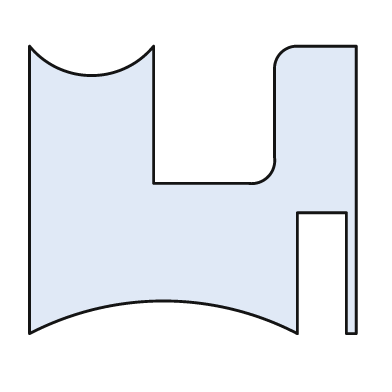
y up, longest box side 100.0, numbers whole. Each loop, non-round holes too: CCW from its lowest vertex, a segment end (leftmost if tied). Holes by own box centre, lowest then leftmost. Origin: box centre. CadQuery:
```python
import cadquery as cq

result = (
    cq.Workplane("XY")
    .moveTo(-50.0, -44.0)
    .threePointArc((-9.0, -34.0), (32.0, -44.0))
    .lineTo(32.0, -7.0)
    .lineTo(47.0, -7.0)
    .lineTo(47.0, -44.0)
    .lineTo(50.0, -44.0)
    .lineTo(50.0, 44.0)
    .lineTo(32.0, 44.0)
    .threePointArc((27.0, 42.0), (25.0, 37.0))
    .lineTo(25.0, 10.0)
    .threePointArc((23.0, 4.0), (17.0, 2.0))
    .lineTo(-12.0, 2.0)
    .lineTo(-12.0, 44.0)
    .threePointArc((-31.0, 35.0), (-50.0, 44.0))
    .close()
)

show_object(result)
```